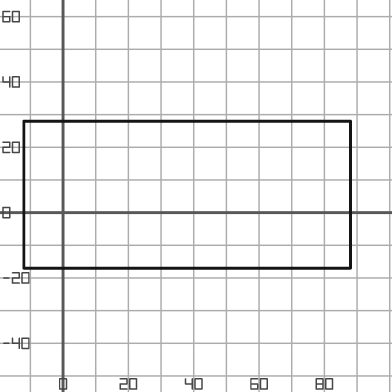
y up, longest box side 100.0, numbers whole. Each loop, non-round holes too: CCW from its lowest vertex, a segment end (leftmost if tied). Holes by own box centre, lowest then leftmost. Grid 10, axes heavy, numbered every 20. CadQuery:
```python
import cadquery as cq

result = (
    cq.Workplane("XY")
    .moveTo(-12.0, -17.0)
    .lineTo(88.0, -17.0)
    .lineTo(88.0, 28.0)
    .lineTo(-12.0, 28.0)
    .close()
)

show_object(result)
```